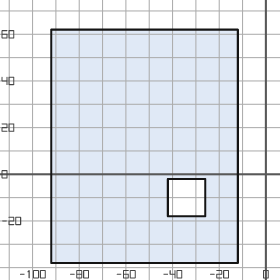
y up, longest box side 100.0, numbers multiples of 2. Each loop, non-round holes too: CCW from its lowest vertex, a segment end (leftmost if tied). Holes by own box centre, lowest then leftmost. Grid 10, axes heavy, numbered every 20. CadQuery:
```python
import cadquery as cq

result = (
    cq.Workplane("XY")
    .moveTo(-92.0, -38.0)
    .lineTo(-12.0, -38.0)
    .lineTo(-12.0, 62.0)
    .lineTo(-92.0, 62.0)
    .close()
    .moveTo(-42.0, -18.0)
    .lineTo(-26.0, -18.0)
    .lineTo(-26.0, -2.0)
    .lineTo(-42.0, -2.0)
    .close()
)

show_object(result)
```